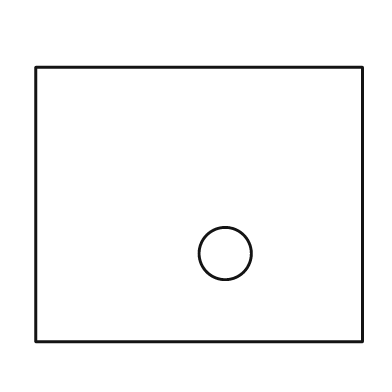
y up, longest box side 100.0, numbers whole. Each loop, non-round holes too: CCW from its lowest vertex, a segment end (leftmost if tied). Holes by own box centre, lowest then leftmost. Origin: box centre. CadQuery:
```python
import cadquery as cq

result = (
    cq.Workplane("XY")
    .moveTo(-50.0, -42.0)
    .lineTo(50.0, -42.0)
    .lineTo(50.0, 42.0)
    .lineTo(-50.0, 42.0)
    .close()
    .moveTo(8.0, -15.0)
    .circle(8.0)
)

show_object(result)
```